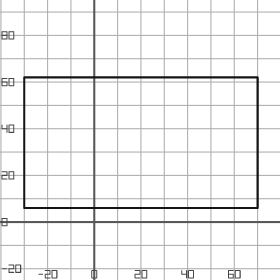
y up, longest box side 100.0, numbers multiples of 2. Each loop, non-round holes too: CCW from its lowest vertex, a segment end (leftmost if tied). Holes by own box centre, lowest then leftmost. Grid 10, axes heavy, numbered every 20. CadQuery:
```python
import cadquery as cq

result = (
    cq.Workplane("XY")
    .moveTo(-30.0, 6.0)
    .lineTo(70.0, 6.0)
    .lineTo(70.0, 62.0)
    .lineTo(-30.0, 62.0)
    .close()
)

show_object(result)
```